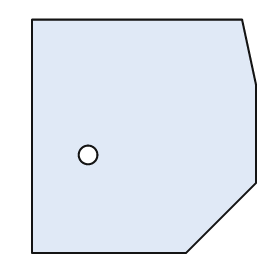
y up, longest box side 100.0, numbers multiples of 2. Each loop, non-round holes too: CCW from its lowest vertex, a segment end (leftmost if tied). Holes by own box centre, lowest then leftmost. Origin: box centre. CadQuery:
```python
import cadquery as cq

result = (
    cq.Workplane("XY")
    .moveTo(-48.0, -50.0)
    .lineTo(18.0, -50.0)
    .lineTo(48.0, -20.0)
    .lineTo(48.0, 22.0)
    .lineTo(42.0, 50.0)
    .lineTo(-48.0, 50.0)
    .close()
    .moveTo(-24.0, -8.0)
    .circle(4.0)
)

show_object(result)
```